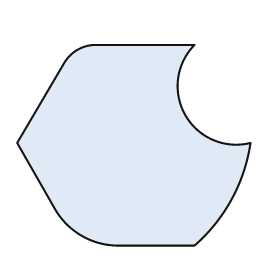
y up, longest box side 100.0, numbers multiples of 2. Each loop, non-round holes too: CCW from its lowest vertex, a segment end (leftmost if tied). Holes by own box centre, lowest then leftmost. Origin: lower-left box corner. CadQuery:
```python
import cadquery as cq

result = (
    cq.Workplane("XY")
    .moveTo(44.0, 0.0)
    .lineTo(76.0, 0.0)
    .threePointArc((92.0, 20.0), (100.0, 44.0))
    .threePointArc((72.0, 56.0), (76.0, 86.0))
    .lineTo(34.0, 86.0)
    .threePointArc((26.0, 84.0), (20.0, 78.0))
    .lineTo(0.0, 44.0)
    .lineTo(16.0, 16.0)
    .threePointArc((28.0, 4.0), (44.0, 0.0))
    .close()
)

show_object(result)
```